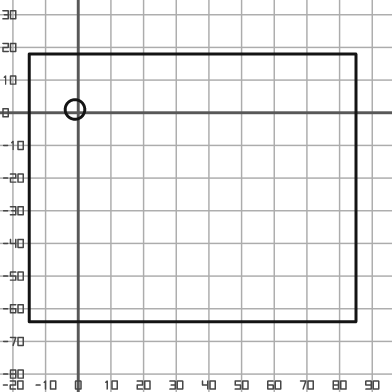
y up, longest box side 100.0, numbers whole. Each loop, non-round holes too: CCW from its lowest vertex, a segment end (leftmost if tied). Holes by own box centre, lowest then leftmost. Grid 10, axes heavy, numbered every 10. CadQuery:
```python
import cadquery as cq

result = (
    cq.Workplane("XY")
    .moveTo(-15.0, -64.0)
    .lineTo(85.0, -64.0)
    .lineTo(85.0, 18.0)
    .lineTo(-15.0, 18.0)
    .close()
    .moveTo(-1.0, 1.0)
    .circle(3.0)
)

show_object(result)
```